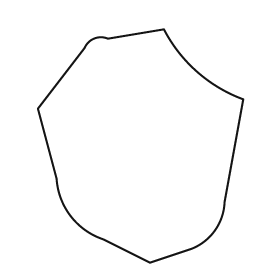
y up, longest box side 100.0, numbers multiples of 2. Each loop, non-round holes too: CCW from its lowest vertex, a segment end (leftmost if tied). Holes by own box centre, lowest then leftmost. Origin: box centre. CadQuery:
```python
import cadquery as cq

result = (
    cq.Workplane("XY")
    .moveTo(4.0, -50.0)
    .lineTo(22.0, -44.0)
    .threePointArc((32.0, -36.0), (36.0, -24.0))
    .lineTo(44.0, 20.0)
    .threePointArc((24.0, 32.0), (10.0, 50.0))
    .lineTo(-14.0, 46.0)
    .threePointArc((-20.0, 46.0), (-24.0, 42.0))
    .lineTo(-44.0, 16.0)
    .lineTo(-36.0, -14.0)
    .threePointArc((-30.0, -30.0), (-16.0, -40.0))
    .close()
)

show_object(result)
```